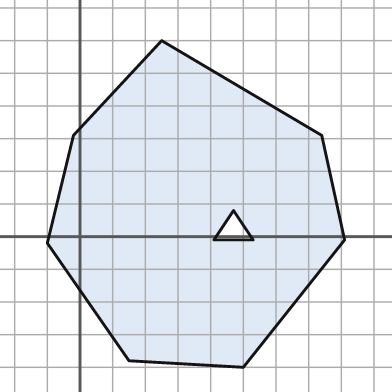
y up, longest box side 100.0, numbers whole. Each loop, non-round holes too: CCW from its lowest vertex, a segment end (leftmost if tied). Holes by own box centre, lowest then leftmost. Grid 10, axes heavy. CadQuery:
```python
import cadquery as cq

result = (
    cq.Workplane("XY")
    .moveTo(50.0, -40.0)
    .lineTo(81.0, -1.0)
    .lineTo(74.0, 31.0)
    .lineTo(25.0, 60.0)
    .lineTo(-2.0, 31.0)
    .lineTo(-10.0, -2.0)
    .lineTo(15.0, -38.0)
    .close()
    .moveTo(41.0, -1.0)
    .lineTo(53.0, -1.0)
    .lineTo(47.0, 8.0)
    .close()
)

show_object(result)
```